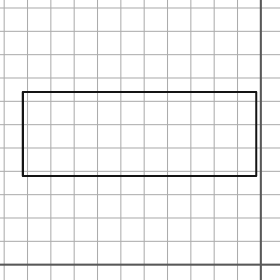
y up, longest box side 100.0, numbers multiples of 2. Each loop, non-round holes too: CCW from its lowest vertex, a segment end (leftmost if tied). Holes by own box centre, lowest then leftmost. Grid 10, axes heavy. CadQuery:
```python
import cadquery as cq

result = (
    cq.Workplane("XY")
    .moveTo(-102.0, 38.0)
    .lineTo(-2.0, 38.0)
    .lineTo(-2.0, 74.0)
    .lineTo(-102.0, 74.0)
    .close()
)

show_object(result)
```